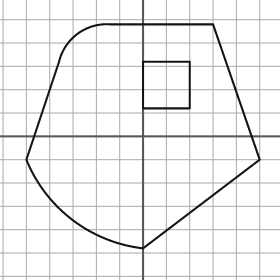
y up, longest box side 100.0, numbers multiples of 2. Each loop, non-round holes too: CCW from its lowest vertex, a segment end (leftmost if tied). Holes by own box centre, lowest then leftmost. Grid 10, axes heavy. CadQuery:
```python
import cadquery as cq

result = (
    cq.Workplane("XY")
    .moveTo(0.0, -48.0)
    .lineTo(50.0, -10.0)
    .lineTo(30.0, 48.0)
    .lineTo(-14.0, 48.0)
    .threePointArc((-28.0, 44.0), (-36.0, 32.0))
    .lineTo(-50.0, -10.0)
    .threePointArc((-30.0, -36.0), (0.0, -48.0))
    .close()
    .moveTo(0.0, 12.0)
    .lineTo(20.0, 12.0)
    .lineTo(20.0, 32.0)
    .lineTo(0.0, 32.0)
    .close()
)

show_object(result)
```